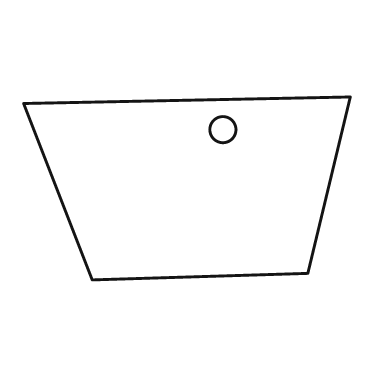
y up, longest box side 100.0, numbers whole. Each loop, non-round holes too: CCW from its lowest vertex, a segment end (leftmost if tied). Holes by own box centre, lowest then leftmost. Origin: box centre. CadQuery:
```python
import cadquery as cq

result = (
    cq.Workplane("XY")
    .moveTo(-29.0, -28.0)
    .lineTo(37.0, -26.0)
    .lineTo(50.0, 28.0)
    .lineTo(-50.0, 26.0)
    .close()
    .moveTo(11.0, 18.0)
    .circle(4.0)
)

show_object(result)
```